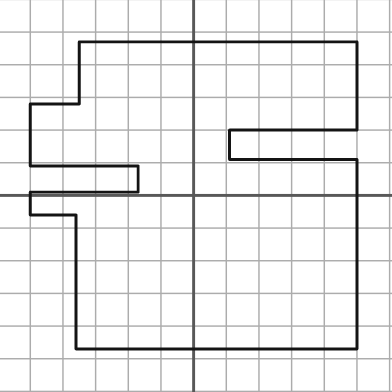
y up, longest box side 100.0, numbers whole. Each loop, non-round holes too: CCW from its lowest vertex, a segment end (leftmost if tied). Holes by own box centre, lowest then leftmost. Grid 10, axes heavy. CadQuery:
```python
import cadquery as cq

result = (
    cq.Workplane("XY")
    .moveTo(-36.0, -47.0)
    .lineTo(50.0, -47.0)
    .lineTo(50.0, 11.0)
    .lineTo(11.0, 11.0)
    .lineTo(11.0, 20.0)
    .lineTo(50.0, 20.0)
    .lineTo(50.0, 47.0)
    .lineTo(-35.0, 47.0)
    .lineTo(-35.0, 28.0)
    .lineTo(-50.0, 28.0)
    .lineTo(-50.0, 9.0)
    .lineTo(-17.0, 9.0)
    .lineTo(-17.0, 1.0)
    .lineTo(-50.0, 1.0)
    .lineTo(-50.0, -6.0)
    .lineTo(-36.0, -6.0)
    .close()
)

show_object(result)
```